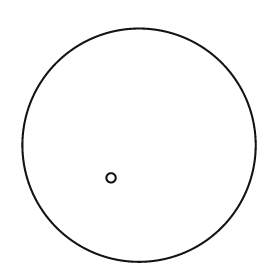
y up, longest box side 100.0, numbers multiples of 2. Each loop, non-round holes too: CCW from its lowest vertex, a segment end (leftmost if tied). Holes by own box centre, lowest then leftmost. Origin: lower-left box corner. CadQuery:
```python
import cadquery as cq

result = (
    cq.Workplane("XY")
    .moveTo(50.0, 50.0)
    .circle(50.0)
    .moveTo(38.0, 36.0)
    .circle(2.0)
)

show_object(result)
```